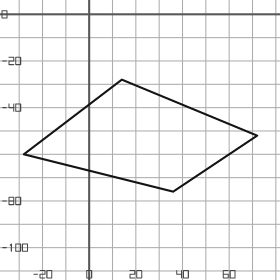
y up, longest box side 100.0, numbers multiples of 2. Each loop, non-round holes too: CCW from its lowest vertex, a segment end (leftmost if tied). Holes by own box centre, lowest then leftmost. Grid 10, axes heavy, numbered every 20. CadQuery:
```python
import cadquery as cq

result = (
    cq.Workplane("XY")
    .moveTo(36.0, -76.0)
    .lineTo(72.0, -52.0)
    .lineTo(14.0, -28.0)
    .lineTo(-28.0, -60.0)
    .close()
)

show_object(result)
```